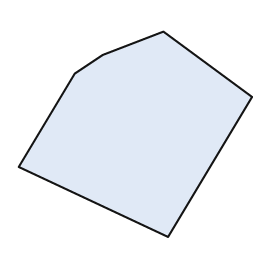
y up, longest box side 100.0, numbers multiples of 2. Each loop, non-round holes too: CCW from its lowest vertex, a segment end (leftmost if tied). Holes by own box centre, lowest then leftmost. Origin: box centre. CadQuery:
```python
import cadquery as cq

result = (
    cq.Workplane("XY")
    .moveTo(14.0, -44.0)
    .lineTo(50.0, 16.0)
    .lineTo(12.0, 44.0)
    .lineTo(-14.0, 34.0)
    .lineTo(-26.0, 26.0)
    .lineTo(-50.0, -14.0)
    .close()
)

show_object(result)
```